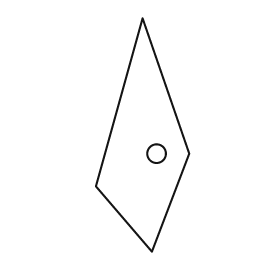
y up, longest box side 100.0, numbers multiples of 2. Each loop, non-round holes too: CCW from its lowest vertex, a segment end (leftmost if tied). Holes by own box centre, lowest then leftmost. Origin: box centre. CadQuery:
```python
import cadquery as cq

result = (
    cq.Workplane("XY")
    .moveTo(4.0, -50.0)
    .lineTo(20.0, -8.0)
    .lineTo(0.0, 50.0)
    .lineTo(-20.0, -22.0)
    .close()
    .moveTo(6.0, -8.0)
    .circle(4.0)
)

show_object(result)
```